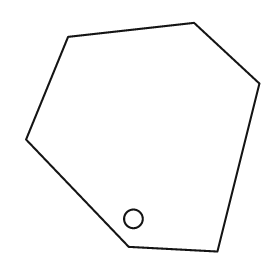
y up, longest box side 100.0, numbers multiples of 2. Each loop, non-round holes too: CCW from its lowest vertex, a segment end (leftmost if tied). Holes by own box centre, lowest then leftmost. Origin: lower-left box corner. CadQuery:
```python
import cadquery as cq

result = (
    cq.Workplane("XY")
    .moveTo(82.0, 0.0)
    .lineTo(100.0, 72.0)
    .lineTo(72.0, 98.0)
    .lineTo(18.0, 92.0)
    .lineTo(0.0, 48.0)
    .lineTo(44.0, 2.0)
    .close()
    .moveTo(46.0, 14.0)
    .circle(4.0)
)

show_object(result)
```